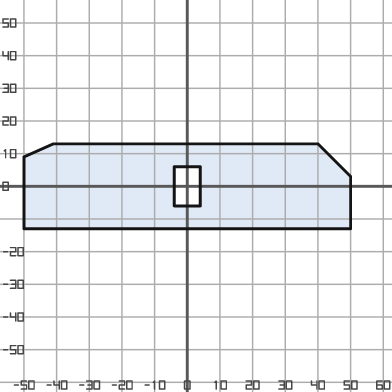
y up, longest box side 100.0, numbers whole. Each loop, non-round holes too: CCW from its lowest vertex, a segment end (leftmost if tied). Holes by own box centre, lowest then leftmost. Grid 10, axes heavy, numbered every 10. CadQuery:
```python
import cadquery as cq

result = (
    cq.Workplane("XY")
    .moveTo(-50.0, -13.0)
    .lineTo(50.0, -13.0)
    .lineTo(50.0, 3.0)
    .lineTo(40.0, 13.0)
    .lineTo(-41.0, 13.0)
    .lineTo(-50.0, 9.0)
    .close()
    .moveTo(-4.0, -6.0)
    .lineTo(4.0, -6.0)
    .lineTo(4.0, 6.0)
    .lineTo(-4.0, 6.0)
    .close()
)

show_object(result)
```